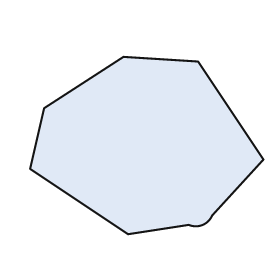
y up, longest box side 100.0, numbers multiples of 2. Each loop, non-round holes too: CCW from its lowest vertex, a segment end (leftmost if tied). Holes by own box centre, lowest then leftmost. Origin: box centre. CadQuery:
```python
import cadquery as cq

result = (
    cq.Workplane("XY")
    .moveTo(-8.0, -38.0)
    .lineTo(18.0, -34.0)
    .threePointArc((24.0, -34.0), (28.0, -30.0))
    .lineTo(50.0, -6.0)
    .lineTo(22.0, 36.0)
    .lineTo(-10.0, 38.0)
    .lineTo(-44.0, 16.0)
    .lineTo(-50.0, -10.0)
    .close()
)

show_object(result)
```